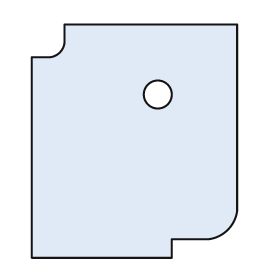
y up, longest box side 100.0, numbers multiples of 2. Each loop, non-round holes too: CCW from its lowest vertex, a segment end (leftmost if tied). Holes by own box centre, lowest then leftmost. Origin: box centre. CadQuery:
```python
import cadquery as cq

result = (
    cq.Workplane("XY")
    .moveTo(-44.0, -50.0)
    .lineTo(16.0, -50.0)
    .lineTo(16.0, -42.0)
    .lineTo(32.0, -42.0)
    .threePointArc((40.0, -38.0), (44.0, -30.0))
    .lineTo(44.0, 50.0)
    .lineTo(-30.0, 50.0)
    .lineTo(-30.0, 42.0)
    .threePointArc((-32.0, 38.0), (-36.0, 36.0))
    .lineTo(-44.0, 36.0)
    .close()
    .moveTo(10.0, 20.0)
    .circle(6.0)
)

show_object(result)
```